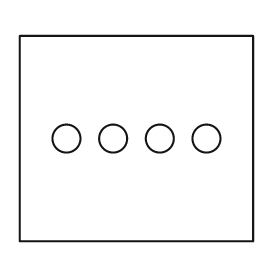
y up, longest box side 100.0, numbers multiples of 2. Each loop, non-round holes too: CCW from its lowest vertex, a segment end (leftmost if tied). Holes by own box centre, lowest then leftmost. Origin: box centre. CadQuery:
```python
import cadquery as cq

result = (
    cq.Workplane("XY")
    .moveTo(-50.0, -44.0)
    .lineTo(50.0, -44.0)
    .lineTo(50.0, 44.0)
    .lineTo(-50.0, 44.0)
    .close()
    .moveTo(-30.0, 0.0)
    .circle(6.0)
    .moveTo(-10.0, 0.0)
    .circle(6.0)
    .moveTo(10.0, 0.0)
    .circle(6.0)
    .moveTo(30.0, 0.0)
    .circle(6.0)
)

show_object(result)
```